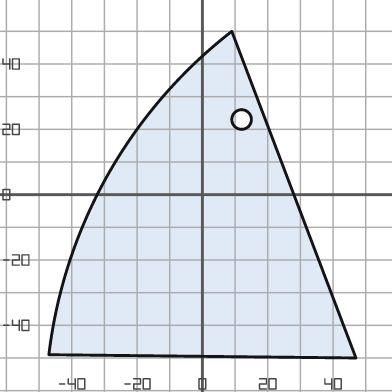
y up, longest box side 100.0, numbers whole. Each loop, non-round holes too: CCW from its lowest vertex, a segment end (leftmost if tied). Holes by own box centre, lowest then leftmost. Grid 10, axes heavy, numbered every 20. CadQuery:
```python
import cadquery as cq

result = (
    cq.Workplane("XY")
    .moveTo(47.0, -50.0)
    .lineTo(9.0, 50.0)
    .threePointArc((-29.0, 6.0), (-47.0, -49.0))
    .close()
    .moveTo(12.0, 23.0)
    .circle(3.0)
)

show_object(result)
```